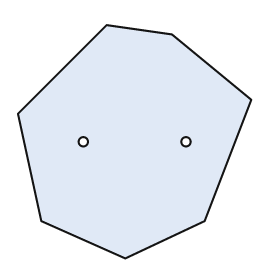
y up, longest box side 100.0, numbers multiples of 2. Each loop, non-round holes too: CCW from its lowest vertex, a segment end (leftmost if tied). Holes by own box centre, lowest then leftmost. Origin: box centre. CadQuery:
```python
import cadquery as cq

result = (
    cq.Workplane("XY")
    .moveTo(-4.0, -50.0)
    .lineTo(30.0, -34.0)
    .lineTo(50.0, 18.0)
    .lineTo(16.0, 46.0)
    .lineTo(-12.0, 50.0)
    .lineTo(-50.0, 12.0)
    .lineTo(-40.0, -34.0)
    .close()
    .moveTo(-22.0, 0.0)
    .circle(2.0)
    .moveTo(22.0, 0.0)
    .circle(2.0)
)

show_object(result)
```